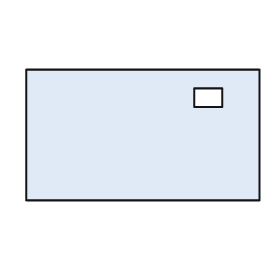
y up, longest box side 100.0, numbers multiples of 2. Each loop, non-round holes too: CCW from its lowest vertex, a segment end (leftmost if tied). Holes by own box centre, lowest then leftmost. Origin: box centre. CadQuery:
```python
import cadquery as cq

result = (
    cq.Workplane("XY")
    .moveTo(-50.0, -28.0)
    .lineTo(50.0, -28.0)
    .lineTo(50.0, 28.0)
    .lineTo(-50.0, 28.0)
    .close()
    .moveTo(22.0, 12.0)
    .lineTo(34.0, 12.0)
    .lineTo(34.0, 20.0)
    .lineTo(22.0, 20.0)
    .close()
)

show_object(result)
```